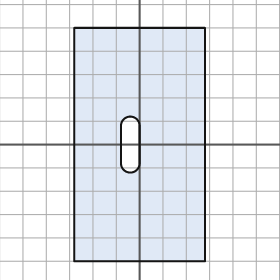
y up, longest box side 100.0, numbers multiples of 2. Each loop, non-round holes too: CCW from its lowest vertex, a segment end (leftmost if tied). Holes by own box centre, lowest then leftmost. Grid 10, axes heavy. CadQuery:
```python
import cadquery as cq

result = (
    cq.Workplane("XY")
    .moveTo(-28.0, -50.0)
    .lineTo(28.0, -50.0)
    .lineTo(28.0, 50.0)
    .lineTo(-28.0, 50.0)
    .close()
    .moveTo(-8.0, -8.0)
    .threePointArc((-4.0, -12.0), (0.0, -8.0))
    .lineTo(0.0, 8.0)
    .threePointArc((-4.0, 12.0), (-8.0, 8.0))
    .close()
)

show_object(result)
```